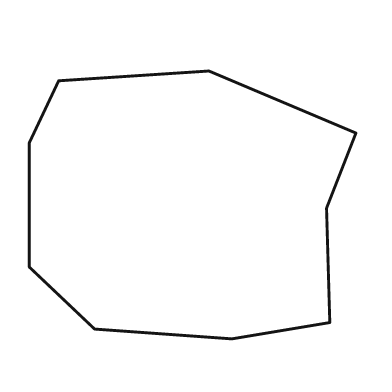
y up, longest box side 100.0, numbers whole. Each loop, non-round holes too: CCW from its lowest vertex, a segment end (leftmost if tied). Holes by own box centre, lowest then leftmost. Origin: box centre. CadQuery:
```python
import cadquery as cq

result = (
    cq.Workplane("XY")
    .moveTo(12.0, -41.0)
    .lineTo(42.0, -36.0)
    .lineTo(41.0, -1.0)
    .lineTo(50.0, 22.0)
    .lineTo(5.0, 41.0)
    .lineTo(-41.0, 38.0)
    .lineTo(-50.0, 19.0)
    .lineTo(-50.0, -19.0)
    .lineTo(-30.0, -38.0)
    .close()
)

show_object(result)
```